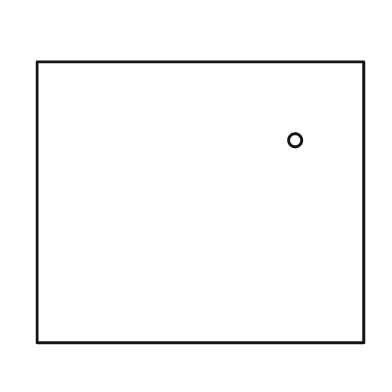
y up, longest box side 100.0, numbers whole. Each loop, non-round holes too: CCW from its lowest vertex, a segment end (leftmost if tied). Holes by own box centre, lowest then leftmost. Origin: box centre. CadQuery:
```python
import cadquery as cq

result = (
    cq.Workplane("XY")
    .moveTo(-50.0, -43.0)
    .lineTo(50.0, -43.0)
    .lineTo(50.0, 43.0)
    .lineTo(-50.0, 43.0)
    .close()
    .moveTo(29.0, 19.0)
    .circle(2.0)
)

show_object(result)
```